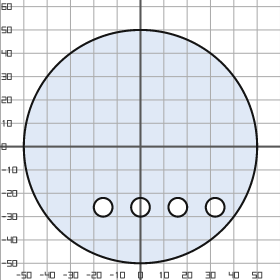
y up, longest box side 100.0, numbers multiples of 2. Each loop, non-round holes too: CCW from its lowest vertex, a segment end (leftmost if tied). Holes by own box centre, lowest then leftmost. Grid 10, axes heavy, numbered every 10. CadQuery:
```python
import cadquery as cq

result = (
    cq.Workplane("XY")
    .moveTo(0.0, 0.0)
    .circle(50.0)
    .moveTo(-16.0, -26.0)
    .circle(4.0)
    .moveTo(0.0, -26.0)
    .circle(4.0)
    .moveTo(16.0, -26.0)
    .circle(4.0)
    .moveTo(32.0, -26.0)
    .circle(4.0)
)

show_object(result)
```